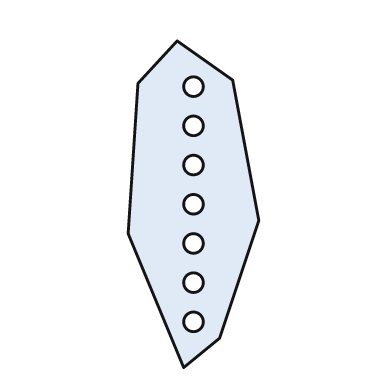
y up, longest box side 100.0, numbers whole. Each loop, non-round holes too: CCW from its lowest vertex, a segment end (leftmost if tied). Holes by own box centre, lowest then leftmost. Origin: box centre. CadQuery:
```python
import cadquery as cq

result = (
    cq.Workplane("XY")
    .moveTo(-3.0, -50.0)
    .lineTo(8.0, -41.0)
    .lineTo(20.0, -5.0)
    .lineTo(12.0, 38.0)
    .lineTo(-5.0, 50.0)
    .lineTo(-17.0, 37.0)
    .lineTo(-20.0, -9.0)
    .close()
    .moveTo(0.0, -36.0)
    .circle(3.0)
    .moveTo(0.0, -24.0)
    .circle(3.0)
    .moveTo(0.0, -12.0)
    .circle(3.0)
    .moveTo(0.0, 0.0)
    .circle(3.0)
    .moveTo(0.0, 12.0)
    .circle(3.0)
    .moveTo(0.0, 24.0)
    .circle(3.0)
    .moveTo(0.0, 36.0)
    .circle(3.0)
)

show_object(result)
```